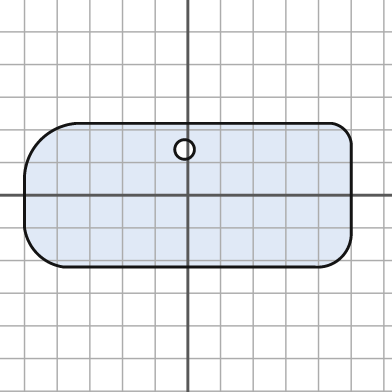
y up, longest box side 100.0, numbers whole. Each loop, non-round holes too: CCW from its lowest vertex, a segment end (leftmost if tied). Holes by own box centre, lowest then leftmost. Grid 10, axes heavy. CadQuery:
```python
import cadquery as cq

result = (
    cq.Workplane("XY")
    .moveTo(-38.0, -22.0)
    .lineTo(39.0, -22.0)
    .threePointArc((47.0, -19.0), (50.0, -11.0))
    .lineTo(50.0, 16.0)
    .threePointArc((48.0, 20.0), (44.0, 22.0))
    .lineTo(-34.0, 22.0)
    .threePointArc((-45.0, 17.0), (-50.0, 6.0))
    .lineTo(-50.0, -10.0)
    .threePointArc((-46.0, -18.0), (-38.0, -22.0))
    .close()
    .moveTo(-1.0, 14.0)
    .circle(3.0)
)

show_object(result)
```